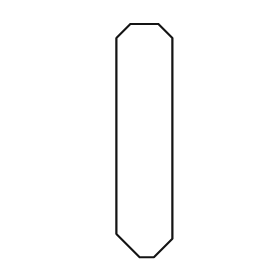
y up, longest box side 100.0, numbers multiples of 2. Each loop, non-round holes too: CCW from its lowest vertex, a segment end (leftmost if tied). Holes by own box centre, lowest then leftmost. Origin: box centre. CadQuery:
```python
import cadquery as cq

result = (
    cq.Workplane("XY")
    .moveTo(-2.0, -50.0)
    .lineTo(4.0, -50.0)
    .lineTo(12.0, -42.0)
    .lineTo(12.0, 44.0)
    .lineTo(6.0, 50.0)
    .lineTo(-6.0, 50.0)
    .lineTo(-12.0, 44.0)
    .lineTo(-12.0, -40.0)
    .close()
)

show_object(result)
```